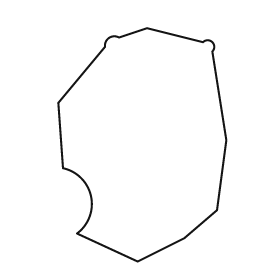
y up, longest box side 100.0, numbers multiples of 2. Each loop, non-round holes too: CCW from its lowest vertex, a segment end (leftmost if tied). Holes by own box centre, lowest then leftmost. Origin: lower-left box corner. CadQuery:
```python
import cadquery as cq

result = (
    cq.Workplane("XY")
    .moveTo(34.0, 0.0)
    .lineTo(54.0, 10.0)
    .lineTo(68.0, 22.0)
    .lineTo(72.0, 52.0)
    .lineTo(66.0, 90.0)
    .threePointArc((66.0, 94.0), (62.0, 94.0))
    .lineTo(38.0, 100.0)
    .lineTo(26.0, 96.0)
    .threePointArc((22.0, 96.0), (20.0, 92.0))
    .lineTo(0.0, 68.0)
    .lineTo(2.0, 40.0)
    .threePointArc((14.0, 28.0), (8.0, 12.0))
    .close()
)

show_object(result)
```